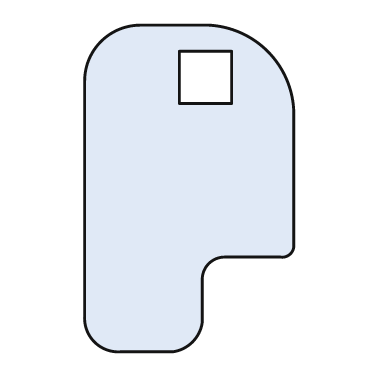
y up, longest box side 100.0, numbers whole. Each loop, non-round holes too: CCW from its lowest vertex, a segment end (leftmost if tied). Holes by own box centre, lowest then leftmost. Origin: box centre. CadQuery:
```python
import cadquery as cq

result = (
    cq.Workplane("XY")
    .moveTo(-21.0, -50.0)
    .lineTo(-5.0, -50.0)
    .threePointArc((1.0, -47.0), (4.0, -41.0))
    .lineTo(4.0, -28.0)
    .threePointArc((6.0, -23.0), (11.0, -21.0))
    .lineTo(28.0, -21.0)
    .threePointArc((31.0, -20.0), (32.0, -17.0))
    .lineTo(32.0, 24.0)
    .threePointArc((24.0, 42.0), (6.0, 50.0))
    .lineTo(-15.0, 50.0)
    .threePointArc((-27.0, 45.0), (-32.0, 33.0))
    .lineTo(-32.0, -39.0)
    .threePointArc((-29.0, -47.0), (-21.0, -50.0))
    .close()
    .moveTo(-3.0, 26.0)
    .lineTo(13.0, 26.0)
    .lineTo(13.0, 42.0)
    .lineTo(-3.0, 42.0)
    .close()
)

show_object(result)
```